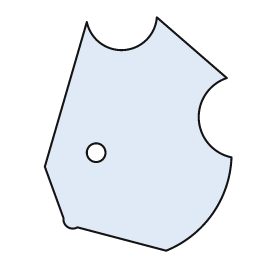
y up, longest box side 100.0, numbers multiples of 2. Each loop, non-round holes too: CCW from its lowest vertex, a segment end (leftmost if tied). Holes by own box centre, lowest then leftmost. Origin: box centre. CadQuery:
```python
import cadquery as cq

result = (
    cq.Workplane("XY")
    .moveTo(12.0, -50.0)
    .threePointArc((32.0, -34.0), (40.0, -10.0))
    .threePointArc((26.0, 6.0), (38.0, 24.0))
    .lineTo(8.0, 50.0)
    .threePointArc((-6.0, 36.0), (-22.0, 48.0))
    .lineTo(-40.0, -14.0)
    .lineTo(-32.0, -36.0)
    .threePointArc((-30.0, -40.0), (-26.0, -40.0))
    .close()
    .moveTo(-18.0, -8.0)
    .circle(4.0)
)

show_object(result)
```